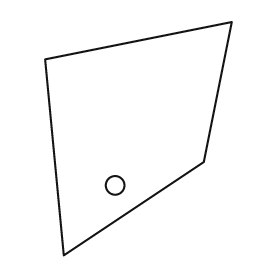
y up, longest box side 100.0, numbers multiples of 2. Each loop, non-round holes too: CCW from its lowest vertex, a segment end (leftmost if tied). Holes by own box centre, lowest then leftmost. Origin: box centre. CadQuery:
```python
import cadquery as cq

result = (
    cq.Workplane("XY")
    .moveTo(-32.0, -50.0)
    .lineTo(28.0, -10.0)
    .lineTo(40.0, 50.0)
    .lineTo(-40.0, 34.0)
    .close()
    .moveTo(-10.0, -20.0)
    .circle(4.0)
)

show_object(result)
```